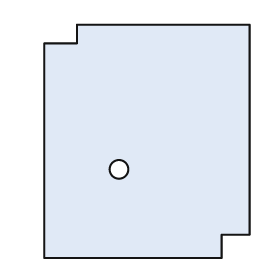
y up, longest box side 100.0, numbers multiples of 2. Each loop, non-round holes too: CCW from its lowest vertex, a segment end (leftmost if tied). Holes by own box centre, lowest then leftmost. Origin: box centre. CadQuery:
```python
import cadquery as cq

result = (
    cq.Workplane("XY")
    .moveTo(-44.0, -50.0)
    .lineTo(32.0, -50.0)
    .lineTo(32.0, -40.0)
    .lineTo(44.0, -40.0)
    .lineTo(44.0, 50.0)
    .lineTo(-30.0, 50.0)
    .lineTo(-30.0, 42.0)
    .lineTo(-44.0, 42.0)
    .close()
    .moveTo(-12.0, -12.0)
    .circle(4.0)
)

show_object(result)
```